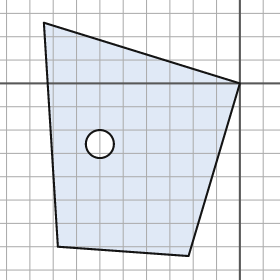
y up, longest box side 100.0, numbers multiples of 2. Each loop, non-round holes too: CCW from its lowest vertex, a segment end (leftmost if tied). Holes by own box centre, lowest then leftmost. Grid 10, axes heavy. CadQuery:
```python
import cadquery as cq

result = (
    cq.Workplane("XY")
    .moveTo(-22.0, -74.0)
    .lineTo(0.0, 0.0)
    .lineTo(-84.0, 26.0)
    .lineTo(-78.0, -70.0)
    .close()
    .moveTo(-60.0, -26.0)
    .circle(6.0)
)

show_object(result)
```